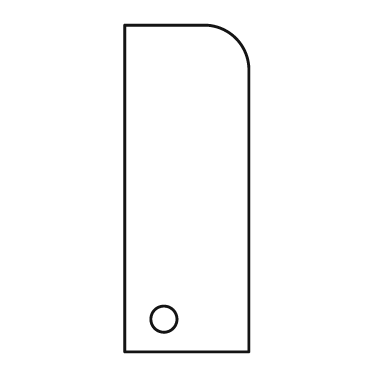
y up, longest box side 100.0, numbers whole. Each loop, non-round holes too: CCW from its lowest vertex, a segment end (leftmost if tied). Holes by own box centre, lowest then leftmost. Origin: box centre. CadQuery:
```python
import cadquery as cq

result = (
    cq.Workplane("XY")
    .moveTo(-19.0, -50.0)
    .lineTo(19.0, -50.0)
    .lineTo(19.0, 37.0)
    .threePointArc((15.0, 46.0), (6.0, 50.0))
    .lineTo(-19.0, 50.0)
    .close()
    .moveTo(-7.0, -40.0)
    .circle(4.0)
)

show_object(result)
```